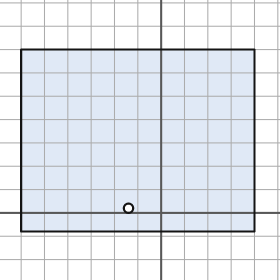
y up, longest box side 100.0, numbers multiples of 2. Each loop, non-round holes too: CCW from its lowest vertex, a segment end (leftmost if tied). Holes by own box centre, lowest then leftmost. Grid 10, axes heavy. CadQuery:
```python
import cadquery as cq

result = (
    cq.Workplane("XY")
    .moveTo(-60.0, -8.0)
    .lineTo(40.0, -8.0)
    .lineTo(40.0, 70.0)
    .lineTo(-60.0, 70.0)
    .close()
    .moveTo(-14.0, 2.0)
    .circle(2.0)
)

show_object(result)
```